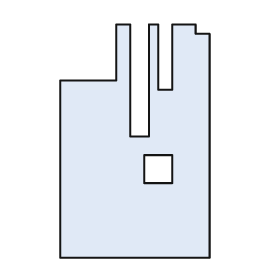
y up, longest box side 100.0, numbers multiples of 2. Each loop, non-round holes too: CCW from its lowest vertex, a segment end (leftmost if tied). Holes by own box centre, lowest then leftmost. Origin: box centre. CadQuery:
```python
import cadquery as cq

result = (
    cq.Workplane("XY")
    .moveTo(-32.0, -50.0)
    .lineTo(32.0, -50.0)
    .lineTo(32.0, 46.0)
    .lineTo(26.0, 46.0)
    .lineTo(26.0, 50.0)
    .lineTo(16.0, 50.0)
    .lineTo(16.0, 22.0)
    .lineTo(10.0, 22.0)
    .lineTo(10.0, 50.0)
    .lineTo(6.0, 50.0)
    .lineTo(6.0, 2.0)
    .lineTo(-2.0, 2.0)
    .lineTo(-2.0, 50.0)
    .lineTo(-8.0, 50.0)
    .lineTo(-8.0, 26.0)
    .lineTo(-32.0, 26.0)
    .close()
    .moveTo(4.0, -18.0)
    .lineTo(16.0, -18.0)
    .lineTo(16.0, -6.0)
    .lineTo(4.0, -6.0)
    .close()
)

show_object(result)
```